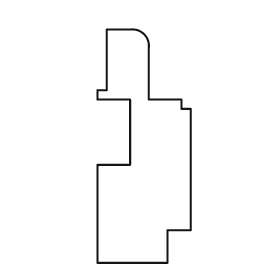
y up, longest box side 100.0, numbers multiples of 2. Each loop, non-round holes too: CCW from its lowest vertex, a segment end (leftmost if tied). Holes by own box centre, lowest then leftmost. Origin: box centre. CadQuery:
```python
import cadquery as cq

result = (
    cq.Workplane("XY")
    .moveTo(-20.0, -50.0)
    .lineTo(10.0, -50.0)
    .lineTo(10.0, -36.0)
    .lineTo(20.0, -36.0)
    .lineTo(20.0, 16.0)
    .lineTo(16.0, 16.0)
    .lineTo(16.0, 20.0)
    .lineTo(2.0, 20.0)
    .lineTo(2.0, 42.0)
    .threePointArc((0.0, 48.0), (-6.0, 50.0))
    .lineTo(-16.0, 50.0)
    .lineTo(-16.0, 24.0)
    .lineTo(-20.0, 24.0)
    .lineTo(-20.0, 20.0)
    .lineTo(-6.0, 20.0)
    .lineTo(-6.0, -8.0)
    .lineTo(-20.0, -8.0)
    .close()
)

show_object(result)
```